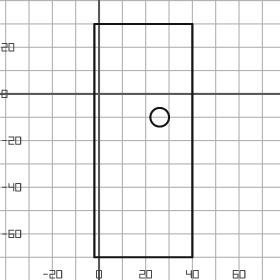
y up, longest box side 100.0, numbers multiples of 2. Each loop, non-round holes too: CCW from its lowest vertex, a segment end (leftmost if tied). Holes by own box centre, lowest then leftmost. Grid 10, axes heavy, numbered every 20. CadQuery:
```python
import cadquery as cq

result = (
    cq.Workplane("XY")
    .moveTo(-2.0, -70.0)
    .lineTo(40.0, -70.0)
    .lineTo(40.0, 30.0)
    .lineTo(-2.0, 30.0)
    .close()
    .moveTo(26.0, -10.0)
    .circle(4.0)
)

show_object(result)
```